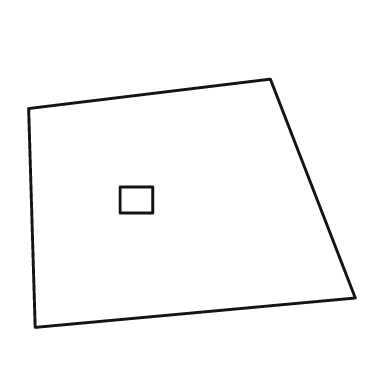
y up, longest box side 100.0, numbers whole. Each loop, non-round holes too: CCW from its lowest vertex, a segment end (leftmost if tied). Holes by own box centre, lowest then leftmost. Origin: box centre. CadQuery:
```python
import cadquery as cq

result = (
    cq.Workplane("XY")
    .moveTo(-48.0, -38.0)
    .lineTo(50.0, -29.0)
    .lineTo(24.0, 38.0)
    .lineTo(-50.0, 29.0)
    .close()
    .moveTo(-22.0, -3.0)
    .lineTo(-12.0, -3.0)
    .lineTo(-12.0, 5.0)
    .lineTo(-22.0, 5.0)
    .close()
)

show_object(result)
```